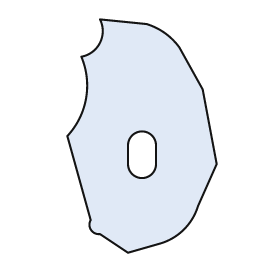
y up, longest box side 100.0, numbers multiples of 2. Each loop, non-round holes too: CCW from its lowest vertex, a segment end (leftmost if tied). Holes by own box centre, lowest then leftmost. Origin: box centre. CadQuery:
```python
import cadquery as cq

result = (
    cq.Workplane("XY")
    .moveTo(-6.0, -50.0)
    .lineTo(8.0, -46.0)
    .threePointArc((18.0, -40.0), (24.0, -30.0))
    .lineTo(32.0, -12.0)
    .lineTo(26.0, 20.0)
    .lineTo(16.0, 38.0)
    .threePointArc((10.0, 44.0), (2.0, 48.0))
    .lineTo(-18.0, 50.0)
    .threePointArc((-18.0, 40.0), (-26.0, 34.0))
    .threePointArc((-24.0, 16.0), (-32.0, 0.0))
    .lineTo(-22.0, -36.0)
    .threePointArc((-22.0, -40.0), (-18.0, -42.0))
    .close()
    .moveTo(-6.0, -12.0)
    .threePointArc((0.0, -18.0), (6.0, -12.0))
    .lineTo(6.0, -4.0)
    .threePointArc((0.0, 2.0), (-6.0, -4.0))
    .close()
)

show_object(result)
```